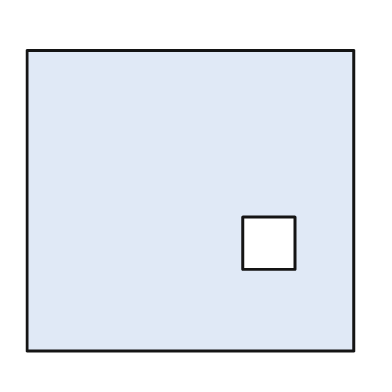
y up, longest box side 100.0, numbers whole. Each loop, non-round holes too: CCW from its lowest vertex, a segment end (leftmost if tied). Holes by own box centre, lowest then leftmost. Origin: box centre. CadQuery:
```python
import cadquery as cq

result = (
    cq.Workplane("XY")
    .moveTo(-50.0, -46.0)
    .lineTo(50.0, -46.0)
    .lineTo(50.0, 46.0)
    .lineTo(-50.0, 46.0)
    .close()
    .moveTo(16.0, -21.0)
    .lineTo(32.0, -21.0)
    .lineTo(32.0, -5.0)
    .lineTo(16.0, -5.0)
    .close()
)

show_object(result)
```